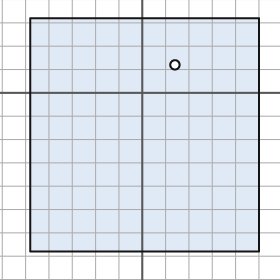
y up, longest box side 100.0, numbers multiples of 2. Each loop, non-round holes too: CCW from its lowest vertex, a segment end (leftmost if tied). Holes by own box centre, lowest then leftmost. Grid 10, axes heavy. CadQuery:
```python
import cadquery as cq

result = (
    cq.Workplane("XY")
    .moveTo(-48.0, -68.0)
    .lineTo(50.0, -68.0)
    .lineTo(50.0, 32.0)
    .lineTo(-48.0, 32.0)
    .close()
    .moveTo(14.0, 12.0)
    .circle(2.0)
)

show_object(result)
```